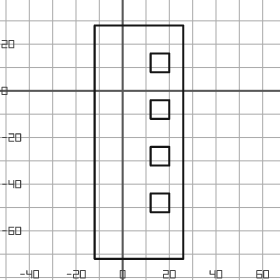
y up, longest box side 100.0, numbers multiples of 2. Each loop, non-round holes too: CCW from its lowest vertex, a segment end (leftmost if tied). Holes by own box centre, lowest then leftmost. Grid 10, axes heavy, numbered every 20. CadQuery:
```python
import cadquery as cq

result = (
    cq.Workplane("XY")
    .moveTo(-12.0, -72.0)
    .lineTo(26.0, -72.0)
    .lineTo(26.0, 28.0)
    .lineTo(-12.0, 28.0)
    .close()
    .moveTo(12.0, -52.0)
    .lineTo(20.0, -52.0)
    .lineTo(20.0, -44.0)
    .lineTo(12.0, -44.0)
    .close()
    .moveTo(12.0, -32.0)
    .lineTo(20.0, -32.0)
    .lineTo(20.0, -24.0)
    .lineTo(12.0, -24.0)
    .close()
    .moveTo(12.0, -12.0)
    .lineTo(20.0, -12.0)
    .lineTo(20.0, -4.0)
    .lineTo(12.0, -4.0)
    .close()
    .moveTo(12.0, 8.0)
    .lineTo(20.0, 8.0)
    .lineTo(20.0, 16.0)
    .lineTo(12.0, 16.0)
    .close()
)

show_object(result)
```